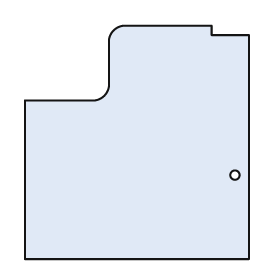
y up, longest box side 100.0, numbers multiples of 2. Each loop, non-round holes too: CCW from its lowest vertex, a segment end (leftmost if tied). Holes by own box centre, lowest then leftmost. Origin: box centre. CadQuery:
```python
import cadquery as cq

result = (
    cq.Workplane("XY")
    .moveTo(-48.0, -50.0)
    .lineTo(48.0, -50.0)
    .lineTo(48.0, 46.0)
    .lineTo(32.0, 46.0)
    .lineTo(32.0, 50.0)
    .lineTo(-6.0, 50.0)
    .threePointArc((-10.0, 48.0), (-12.0, 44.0))
    .lineTo(-12.0, 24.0)
    .threePointArc((-14.0, 20.0), (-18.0, 18.0))
    .lineTo(-48.0, 18.0)
    .close()
    .moveTo(42.0, -14.0)
    .circle(2.0)
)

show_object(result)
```